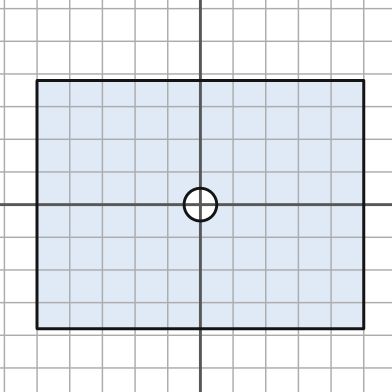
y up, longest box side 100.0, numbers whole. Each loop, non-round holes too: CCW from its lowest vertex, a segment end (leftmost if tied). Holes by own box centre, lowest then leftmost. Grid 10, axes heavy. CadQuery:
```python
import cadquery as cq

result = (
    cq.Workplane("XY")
    .moveTo(-50.0, -38.0)
    .lineTo(50.0, -38.0)
    .lineTo(50.0, 38.0)
    .lineTo(-50.0, 38.0)
    .close()
    .moveTo(0.0, 0.0)
    .circle(5.0)
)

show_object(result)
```